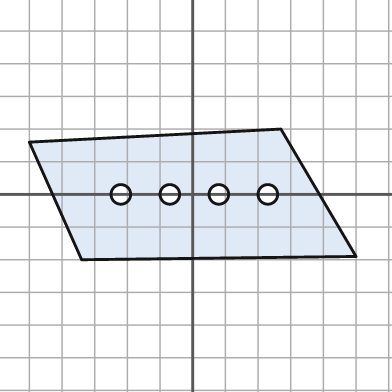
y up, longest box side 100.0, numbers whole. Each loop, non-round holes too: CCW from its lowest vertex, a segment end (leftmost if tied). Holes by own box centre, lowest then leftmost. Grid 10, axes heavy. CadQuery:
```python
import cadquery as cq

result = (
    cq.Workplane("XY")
    .moveTo(-34.0, -20.0)
    .lineTo(50.0, -19.0)
    .lineTo(27.0, 20.0)
    .lineTo(-50.0, 16.0)
    .close()
    .moveTo(-22.0, 0.0)
    .circle(3.0)
    .moveTo(-7.0, 0.0)
    .circle(3.0)
    .moveTo(8.0, 0.0)
    .circle(3.0)
    .moveTo(23.0, 0.0)
    .circle(3.0)
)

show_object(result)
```